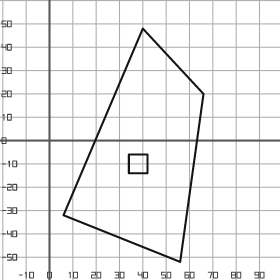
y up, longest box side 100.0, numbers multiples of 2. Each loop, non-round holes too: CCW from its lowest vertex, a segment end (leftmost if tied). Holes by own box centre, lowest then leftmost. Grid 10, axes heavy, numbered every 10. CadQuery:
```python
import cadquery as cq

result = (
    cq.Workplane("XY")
    .moveTo(56.0, -52.0)
    .lineTo(66.0, 20.0)
    .lineTo(40.0, 48.0)
    .lineTo(6.0, -32.0)
    .close()
    .moveTo(34.0, -14.0)
    .lineTo(42.0, -14.0)
    .lineTo(42.0, -6.0)
    .lineTo(34.0, -6.0)
    .close()
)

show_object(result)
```